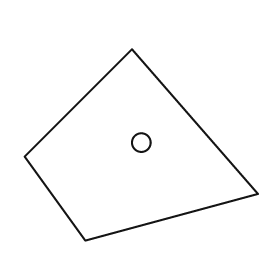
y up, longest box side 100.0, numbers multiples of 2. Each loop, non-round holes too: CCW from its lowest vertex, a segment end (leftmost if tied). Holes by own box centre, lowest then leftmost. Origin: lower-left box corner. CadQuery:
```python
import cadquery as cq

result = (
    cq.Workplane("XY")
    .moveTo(26.0, 0.0)
    .lineTo(100.0, 20.0)
    .lineTo(46.0, 82.0)
    .lineTo(0.0, 36.0)
    .close()
    .moveTo(50.0, 42.0)
    .circle(4.0)
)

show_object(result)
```